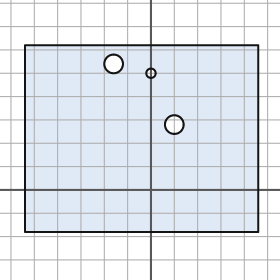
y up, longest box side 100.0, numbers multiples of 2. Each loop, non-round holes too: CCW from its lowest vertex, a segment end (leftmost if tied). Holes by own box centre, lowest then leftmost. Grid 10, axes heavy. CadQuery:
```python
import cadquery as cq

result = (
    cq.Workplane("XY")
    .moveTo(-54.0, -18.0)
    .lineTo(46.0, -18.0)
    .lineTo(46.0, 62.0)
    .lineTo(-54.0, 62.0)
    .close()
    .moveTo(10.0, 28.0)
    .circle(4.0)
    .moveTo(0.0, 50.0)
    .circle(2.0)
    .moveTo(-16.0, 54.0)
    .circle(4.0)
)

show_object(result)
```